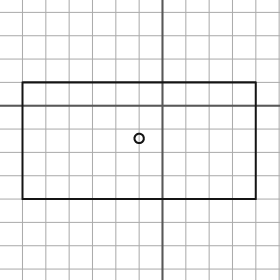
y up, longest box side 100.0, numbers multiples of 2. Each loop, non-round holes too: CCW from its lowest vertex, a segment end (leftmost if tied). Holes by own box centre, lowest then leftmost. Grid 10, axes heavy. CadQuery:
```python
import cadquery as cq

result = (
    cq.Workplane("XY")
    .moveTo(-60.0, -40.0)
    .lineTo(40.0, -40.0)
    .lineTo(40.0, 10.0)
    .lineTo(-60.0, 10.0)
    .close()
    .moveTo(-10.0, -14.0)
    .circle(2.0)
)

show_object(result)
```